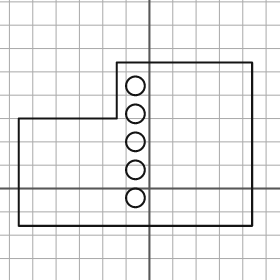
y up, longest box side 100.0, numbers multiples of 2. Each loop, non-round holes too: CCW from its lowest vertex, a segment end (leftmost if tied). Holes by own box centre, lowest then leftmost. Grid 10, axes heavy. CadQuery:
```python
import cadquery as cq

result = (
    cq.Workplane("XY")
    .moveTo(-56.0, -16.0)
    .lineTo(44.0, -16.0)
    .lineTo(44.0, 54.0)
    .lineTo(-14.0, 54.0)
    .lineTo(-14.0, 30.0)
    .lineTo(-56.0, 30.0)
    .close()
    .moveTo(-6.0, -4.0)
    .circle(4.0)
    .moveTo(-6.0, 8.0)
    .circle(4.0)
    .moveTo(-6.0, 20.0)
    .circle(4.0)
    .moveTo(-6.0, 32.0)
    .circle(4.0)
    .moveTo(-6.0, 44.0)
    .circle(4.0)
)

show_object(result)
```